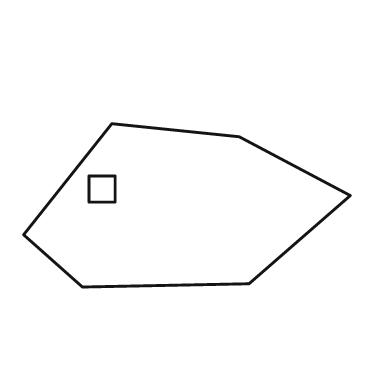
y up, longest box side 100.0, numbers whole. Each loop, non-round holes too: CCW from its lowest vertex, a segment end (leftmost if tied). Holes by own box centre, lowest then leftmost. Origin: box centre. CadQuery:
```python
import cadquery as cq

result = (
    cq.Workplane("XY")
    .moveTo(-32.0, -25.0)
    .lineTo(19.0, -24.0)
    .lineTo(50.0, 3.0)
    .lineTo(16.0, 21.0)
    .lineTo(-23.0, 25.0)
    .lineTo(-50.0, -9.0)
    .close()
    .moveTo(-30.0, 1.0)
    .lineTo(-22.0, 1.0)
    .lineTo(-22.0, 9.0)
    .lineTo(-30.0, 9.0)
    .close()
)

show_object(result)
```